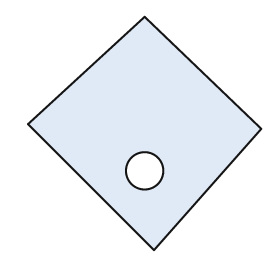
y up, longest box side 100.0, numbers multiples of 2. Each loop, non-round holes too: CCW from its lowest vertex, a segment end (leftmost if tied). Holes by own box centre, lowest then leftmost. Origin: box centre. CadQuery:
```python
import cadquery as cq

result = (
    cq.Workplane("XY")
    .moveTo(4.0, -50.0)
    .lineTo(50.0, 2.0)
    .lineTo(0.0, 50.0)
    .lineTo(-50.0, 4.0)
    .close()
    .moveTo(0.0, -16.0)
    .circle(8.0)
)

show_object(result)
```